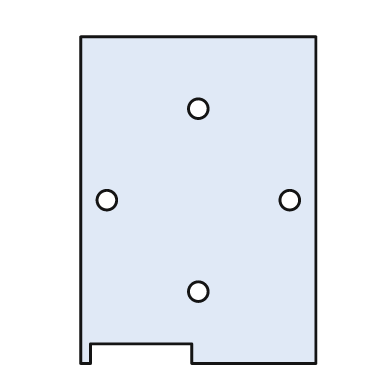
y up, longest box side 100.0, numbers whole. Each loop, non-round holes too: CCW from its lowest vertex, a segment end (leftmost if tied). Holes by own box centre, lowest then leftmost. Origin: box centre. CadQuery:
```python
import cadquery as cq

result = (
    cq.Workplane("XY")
    .moveTo(-36.0, -50.0)
    .lineTo(-33.0, -50.0)
    .lineTo(-33.0, -44.0)
    .lineTo(-2.0, -44.0)
    .lineTo(-2.0, -50.0)
    .lineTo(36.0, -50.0)
    .lineTo(36.0, 50.0)
    .lineTo(-36.0, 50.0)
    .close()
    .moveTo(0.0, -28.0)
    .circle(3.0)
    .moveTo(-28.0, 0.0)
    .circle(3.0)
    .moveTo(28.0, 0.0)
    .circle(3.0)
    .moveTo(0.0, 28.0)
    .circle(3.0)
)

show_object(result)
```